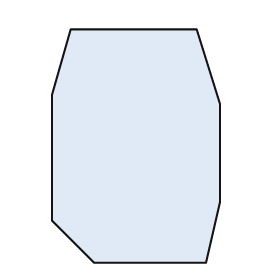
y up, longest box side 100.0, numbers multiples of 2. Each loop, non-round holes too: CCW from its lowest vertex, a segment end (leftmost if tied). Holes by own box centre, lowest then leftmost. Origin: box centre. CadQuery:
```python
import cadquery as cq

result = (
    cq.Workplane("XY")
    .moveTo(-18.0, -50.0)
    .lineTo(30.0, -50.0)
    .lineTo(36.0, -24.0)
    .lineTo(36.0, 18.0)
    .lineTo(26.0, 50.0)
    .lineTo(-28.0, 50.0)
    .lineTo(-36.0, 22.0)
    .lineTo(-36.0, -32.0)
    .close()
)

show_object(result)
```